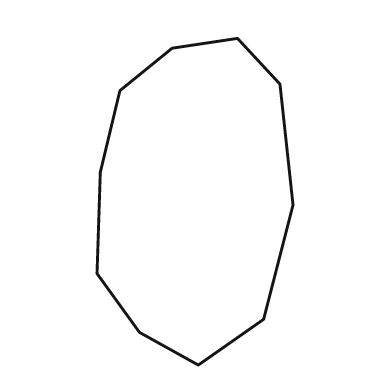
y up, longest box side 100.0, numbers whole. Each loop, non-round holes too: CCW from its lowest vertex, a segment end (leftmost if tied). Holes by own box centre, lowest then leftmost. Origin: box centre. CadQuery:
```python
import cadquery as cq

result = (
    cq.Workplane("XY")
    .moveTo(1.0, -50.0)
    .lineTo(21.0, -36.0)
    .lineTo(30.0, -1.0)
    .lineTo(26.0, 36.0)
    .lineTo(13.0, 50.0)
    .lineTo(-7.0, 47.0)
    .lineTo(-23.0, 34.0)
    .lineTo(-29.0, 9.0)
    .lineTo(-30.0, -22.0)
    .lineTo(-17.0, -40.0)
    .close()
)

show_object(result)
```